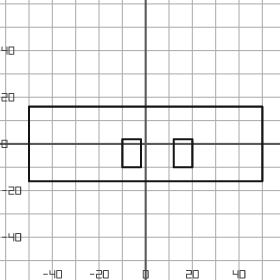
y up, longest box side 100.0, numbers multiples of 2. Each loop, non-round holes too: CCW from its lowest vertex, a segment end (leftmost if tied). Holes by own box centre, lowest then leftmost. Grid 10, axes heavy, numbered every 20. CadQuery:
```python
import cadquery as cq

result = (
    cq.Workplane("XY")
    .moveTo(-50.0, -16.0)
    .lineTo(50.0, -16.0)
    .lineTo(50.0, 16.0)
    .lineTo(-50.0, 16.0)
    .close()
    .moveTo(-10.0, -10.0)
    .lineTo(-2.0, -10.0)
    .lineTo(-2.0, 2.0)
    .lineTo(-10.0, 2.0)
    .close()
    .moveTo(12.0, -10.0)
    .lineTo(20.0, -10.0)
    .lineTo(20.0, 2.0)
    .lineTo(12.0, 2.0)
    .close()
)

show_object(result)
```